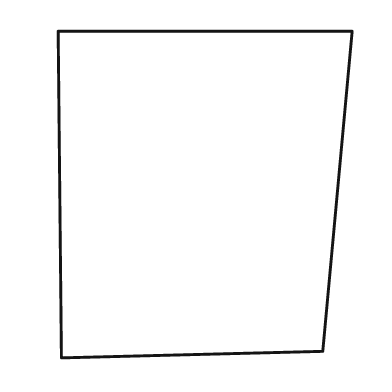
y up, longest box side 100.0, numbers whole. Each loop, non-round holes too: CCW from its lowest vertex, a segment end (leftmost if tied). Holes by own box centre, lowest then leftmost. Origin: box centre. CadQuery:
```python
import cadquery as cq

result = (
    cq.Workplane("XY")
    .moveTo(-44.0, -50.0)
    .lineTo(36.0, -48.0)
    .lineTo(45.0, 50.0)
    .lineTo(-45.0, 50.0)
    .close()
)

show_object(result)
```